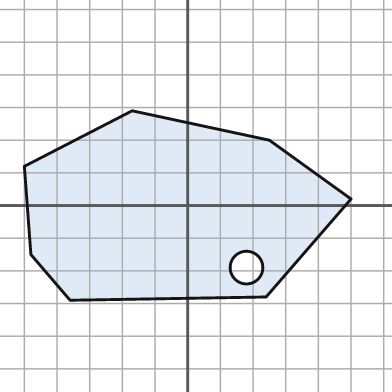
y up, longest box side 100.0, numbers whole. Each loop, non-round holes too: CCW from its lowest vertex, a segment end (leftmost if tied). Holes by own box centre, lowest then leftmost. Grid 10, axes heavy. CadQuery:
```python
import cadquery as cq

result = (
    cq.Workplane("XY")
    .moveTo(-36.0, -29.0)
    .lineTo(24.0, -28.0)
    .lineTo(50.0, 2.0)
    .lineTo(25.0, 20.0)
    .lineTo(-17.0, 29.0)
    .lineTo(-50.0, 12.0)
    .lineTo(-48.0, -15.0)
    .close()
    .moveTo(18.0, -19.0)
    .circle(5.0)
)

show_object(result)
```